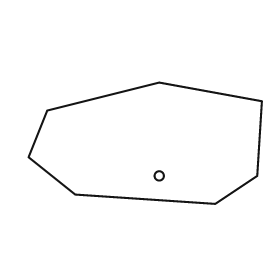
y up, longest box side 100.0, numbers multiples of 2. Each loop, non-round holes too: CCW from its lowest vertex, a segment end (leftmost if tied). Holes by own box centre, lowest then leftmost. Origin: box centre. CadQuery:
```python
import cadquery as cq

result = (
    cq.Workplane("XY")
    .moveTo(30.0, -26.0)
    .lineTo(48.0, -14.0)
    .lineTo(50.0, 18.0)
    .lineTo(6.0, 26.0)
    .lineTo(-42.0, 14.0)
    .lineTo(-50.0, -6.0)
    .lineTo(-30.0, -22.0)
    .close()
    .moveTo(6.0, -14.0)
    .circle(2.0)
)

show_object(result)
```